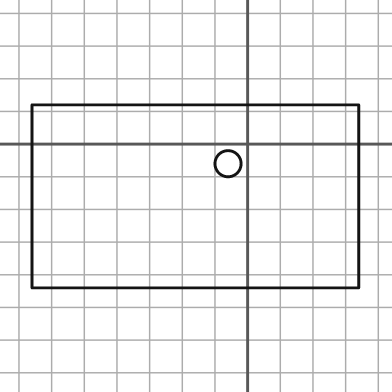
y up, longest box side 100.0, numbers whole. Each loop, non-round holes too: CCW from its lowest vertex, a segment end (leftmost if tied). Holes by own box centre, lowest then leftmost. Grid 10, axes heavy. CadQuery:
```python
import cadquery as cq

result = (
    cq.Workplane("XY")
    .moveTo(-66.0, -44.0)
    .lineTo(34.0, -44.0)
    .lineTo(34.0, 12.0)
    .lineTo(-66.0, 12.0)
    .close()
    .moveTo(-6.0, -6.0)
    .circle(4.0)
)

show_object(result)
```